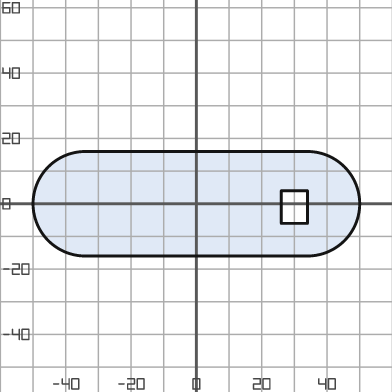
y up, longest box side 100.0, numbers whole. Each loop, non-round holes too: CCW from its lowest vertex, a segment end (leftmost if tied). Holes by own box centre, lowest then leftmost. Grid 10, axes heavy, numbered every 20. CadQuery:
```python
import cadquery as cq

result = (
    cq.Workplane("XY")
    .moveTo(-34.0, -16.0)
    .lineTo(34.0, -16.0)
    .threePointArc((50.0, 0.0), (34.0, 16.0))
    .lineTo(-34.0, 16.0)
    .threePointArc((-50.0, 0.0), (-34.0, -16.0))
    .close()
    .moveTo(26.0, -6.0)
    .lineTo(34.0, -6.0)
    .lineTo(34.0, 4.0)
    .lineTo(26.0, 4.0)
    .close()
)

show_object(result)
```